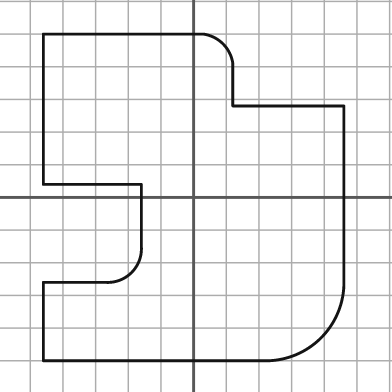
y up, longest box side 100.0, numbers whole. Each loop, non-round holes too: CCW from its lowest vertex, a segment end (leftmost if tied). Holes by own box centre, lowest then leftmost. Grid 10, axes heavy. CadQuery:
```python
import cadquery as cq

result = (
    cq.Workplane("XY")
    .moveTo(-46.0, -50.0)
    .lineTo(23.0, -50.0)
    .threePointArc((39.0, -43.0), (46.0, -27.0))
    .lineTo(46.0, 28.0)
    .lineTo(12.0, 28.0)
    .lineTo(12.0, 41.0)
    .threePointArc((9.0, 47.0), (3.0, 50.0))
    .lineTo(-46.0, 50.0)
    .lineTo(-46.0, 4.0)
    .lineTo(-16.0, 4.0)
    .lineTo(-16.0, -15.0)
    .threePointArc((-19.0, -23.0), (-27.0, -26.0))
    .lineTo(-46.0, -26.0)
    .close()
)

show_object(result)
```